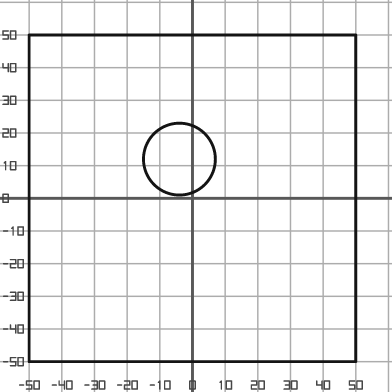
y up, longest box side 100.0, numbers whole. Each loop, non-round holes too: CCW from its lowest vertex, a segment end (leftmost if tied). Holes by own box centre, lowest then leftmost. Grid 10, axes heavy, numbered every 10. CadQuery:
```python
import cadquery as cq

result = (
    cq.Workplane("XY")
    .moveTo(-50.0, -50.0)
    .lineTo(50.0, -50.0)
    .lineTo(50.0, 50.0)
    .lineTo(-50.0, 50.0)
    .close()
    .moveTo(-4.0, 12.0)
    .circle(11.0)
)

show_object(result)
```